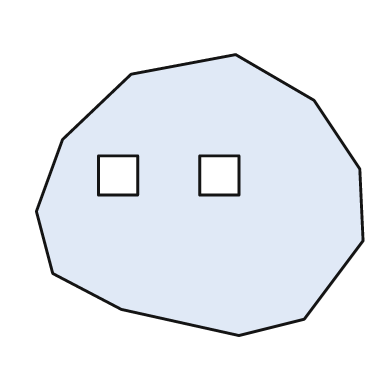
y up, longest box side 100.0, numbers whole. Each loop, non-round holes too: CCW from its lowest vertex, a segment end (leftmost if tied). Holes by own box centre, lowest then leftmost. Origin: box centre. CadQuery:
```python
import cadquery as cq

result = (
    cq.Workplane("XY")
    .moveTo(12.0, -43.0)
    .lineTo(32.0, -38.0)
    .lineTo(50.0, -14.0)
    .lineTo(49.0, 8.0)
    .lineTo(35.0, 29.0)
    .lineTo(11.0, 43.0)
    .lineTo(-21.0, 37.0)
    .lineTo(-42.0, 17.0)
    .lineTo(-50.0, -5.0)
    .lineTo(-45.0, -24.0)
    .lineTo(-24.0, -35.0)
    .close()
    .moveTo(-31.0, 0.0)
    .lineTo(-19.0, 0.0)
    .lineTo(-19.0, 12.0)
    .lineTo(-31.0, 12.0)
    .close()
    .moveTo(0.0, 0.0)
    .lineTo(12.0, 0.0)
    .lineTo(12.0, 12.0)
    .lineTo(0.0, 12.0)
    .close()
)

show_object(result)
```